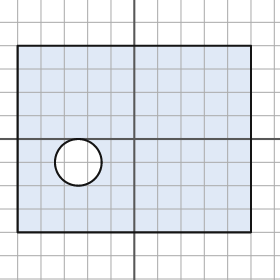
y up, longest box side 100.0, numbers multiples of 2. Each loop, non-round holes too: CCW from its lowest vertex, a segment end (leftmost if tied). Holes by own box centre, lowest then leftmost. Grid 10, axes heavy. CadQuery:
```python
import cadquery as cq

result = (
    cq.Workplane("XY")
    .moveTo(-50.0, -40.0)
    .lineTo(50.0, -40.0)
    .lineTo(50.0, 40.0)
    .lineTo(-50.0, 40.0)
    .close()
    .moveTo(-24.0, -10.0)
    .circle(10.0)
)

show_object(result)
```